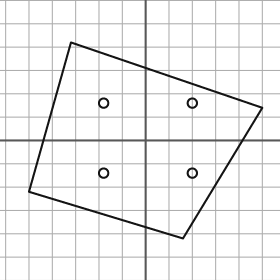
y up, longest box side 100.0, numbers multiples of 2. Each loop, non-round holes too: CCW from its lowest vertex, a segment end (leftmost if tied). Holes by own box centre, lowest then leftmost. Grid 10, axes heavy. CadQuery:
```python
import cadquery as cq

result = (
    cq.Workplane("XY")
    .moveTo(16.0, -42.0)
    .lineTo(50.0, 14.0)
    .lineTo(-32.0, 42.0)
    .lineTo(-50.0, -22.0)
    .close()
    .moveTo(-18.0, -14.0)
    .circle(2.0)
    .moveTo(20.0, -14.0)
    .circle(2.0)
    .moveTo(-18.0, 16.0)
    .circle(2.0)
    .moveTo(20.0, 16.0)
    .circle(2.0)
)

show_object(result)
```